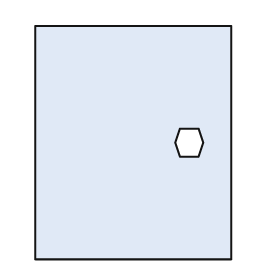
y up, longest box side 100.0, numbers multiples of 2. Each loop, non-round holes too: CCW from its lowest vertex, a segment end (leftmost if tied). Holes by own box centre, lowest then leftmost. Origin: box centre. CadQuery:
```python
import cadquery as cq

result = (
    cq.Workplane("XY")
    .moveTo(-42.0, -50.0)
    .lineTo(42.0, -50.0)
    .lineTo(42.0, 50.0)
    .lineTo(-42.0, 50.0)
    .close()
    .moveTo(20.0, -6.0)
    .lineTo(28.0, -6.0)
    .lineTo(30.0, 0.0)
    .lineTo(28.0, 6.0)
    .lineTo(20.0, 6.0)
    .lineTo(18.0, 0.0)
    .close()
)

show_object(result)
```